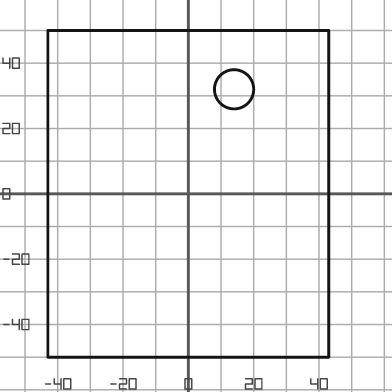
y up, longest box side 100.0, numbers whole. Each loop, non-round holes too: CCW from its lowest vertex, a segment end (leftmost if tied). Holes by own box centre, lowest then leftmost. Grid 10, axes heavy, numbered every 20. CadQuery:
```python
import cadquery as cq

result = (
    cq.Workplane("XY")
    .moveTo(-43.0, -50.0)
    .lineTo(43.0, -50.0)
    .lineTo(43.0, 50.0)
    .lineTo(-43.0, 50.0)
    .close()
    .moveTo(14.0, 32.0)
    .circle(6.0)
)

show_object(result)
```